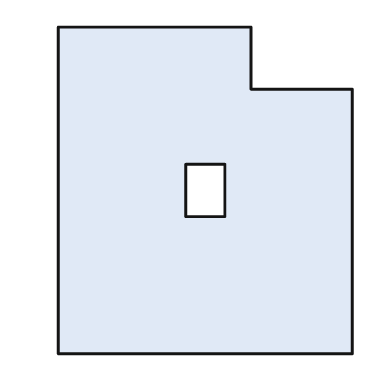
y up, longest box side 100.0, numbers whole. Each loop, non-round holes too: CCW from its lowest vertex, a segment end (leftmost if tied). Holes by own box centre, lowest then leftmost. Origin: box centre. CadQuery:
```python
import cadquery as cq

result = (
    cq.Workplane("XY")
    .moveTo(-45.0, -50.0)
    .lineTo(45.0, -50.0)
    .lineTo(45.0, 31.0)
    .lineTo(14.0, 31.0)
    .lineTo(14.0, 50.0)
    .lineTo(-45.0, 50.0)
    .close()
    .moveTo(-6.0, -8.0)
    .lineTo(6.0, -8.0)
    .lineTo(6.0, 8.0)
    .lineTo(-6.0, 8.0)
    .close()
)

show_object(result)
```